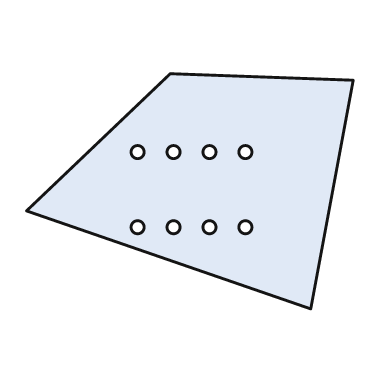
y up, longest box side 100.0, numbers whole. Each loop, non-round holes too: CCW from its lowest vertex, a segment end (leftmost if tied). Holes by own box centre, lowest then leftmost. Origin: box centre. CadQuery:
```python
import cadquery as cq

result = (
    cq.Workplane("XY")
    .moveTo(37.0, -36.0)
    .lineTo(50.0, 34.0)
    .lineTo(-6.0, 36.0)
    .lineTo(-50.0, -6.0)
    .close()
    .moveTo(-16.0, -11.0)
    .circle(2.0)
    .moveTo(-5.0, -11.0)
    .circle(2.0)
    .moveTo(6.0, -11.0)
    .circle(2.0)
    .moveTo(17.0, -11.0)
    .circle(2.0)
    .moveTo(-16.0, 12.0)
    .circle(2.0)
    .moveTo(-5.0, 12.0)
    .circle(2.0)
    .moveTo(6.0, 12.0)
    .circle(2.0)
    .moveTo(17.0, 12.0)
    .circle(2.0)
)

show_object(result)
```